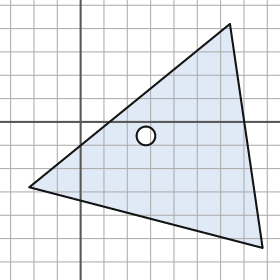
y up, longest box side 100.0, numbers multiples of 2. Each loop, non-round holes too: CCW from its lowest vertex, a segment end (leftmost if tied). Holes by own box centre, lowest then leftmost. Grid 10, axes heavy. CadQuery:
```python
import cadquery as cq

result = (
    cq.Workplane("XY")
    .moveTo(78.0, -54.0)
    .lineTo(64.0, 42.0)
    .lineTo(-22.0, -28.0)
    .close()
    .moveTo(28.0, -6.0)
    .circle(4.0)
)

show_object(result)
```